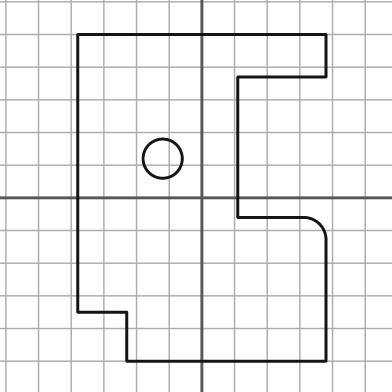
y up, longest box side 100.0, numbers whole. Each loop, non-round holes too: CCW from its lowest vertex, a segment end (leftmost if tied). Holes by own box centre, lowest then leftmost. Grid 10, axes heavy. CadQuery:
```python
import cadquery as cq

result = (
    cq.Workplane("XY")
    .moveTo(-23.0, -50.0)
    .lineTo(38.0, -50.0)
    .lineTo(38.0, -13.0)
    .threePointArc((36.0, -8.0), (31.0, -6.0))
    .lineTo(11.0, -6.0)
    .lineTo(11.0, 37.0)
    .lineTo(38.0, 37.0)
    .lineTo(38.0, 50.0)
    .lineTo(-38.0, 50.0)
    .lineTo(-38.0, -35.0)
    .lineTo(-23.0, -35.0)
    .close()
    .moveTo(-12.0, 12.0)
    .circle(6.0)
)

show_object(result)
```